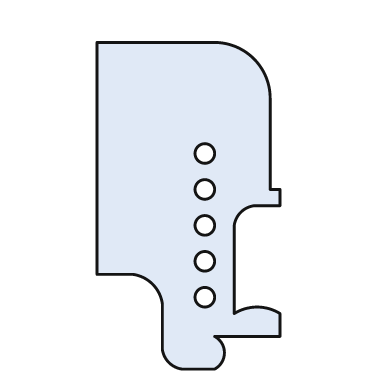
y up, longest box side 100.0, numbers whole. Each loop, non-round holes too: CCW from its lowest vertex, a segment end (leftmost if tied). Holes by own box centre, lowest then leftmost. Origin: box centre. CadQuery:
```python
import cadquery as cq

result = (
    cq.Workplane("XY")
    .moveTo(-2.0, -50.0)
    .lineTo(8.0, -50.0)
    .threePointArc((11.0, -45.0), (8.0, -40.0))
    .lineTo(28.0, -40.0)
    .lineTo(28.0, -33.0)
    .threePointArc((21.0, -31.0), (14.0, -33.0))
    .lineTo(14.0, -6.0)
    .threePointArc((16.0, -2.0), (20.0, 0.0))
    .lineTo(28.0, 0.0)
    .lineTo(28.0, 5.0)
    .lineTo(25.0, 5.0)
    .lineTo(25.0, 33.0)
    .threePointArc((20.0, 45.0), (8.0, 50.0))
    .lineTo(-28.0, 50.0)
    .lineTo(-28.0, -21.0)
    .lineTo(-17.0, -21.0)
    .threePointArc((-11.0, -24.0), (-8.0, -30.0))
    .lineTo(-8.0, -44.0)
    .threePointArc((-6.0, -48.0), (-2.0, -50.0))
    .close()
    .moveTo(5.0, -28.0)
    .circle(3.0)
    .moveTo(5.0, -17.0)
    .circle(3.0)
    .moveTo(5.0, -6.0)
    .circle(3.0)
    .moveTo(5.0, 5.0)
    .circle(3.0)
    .moveTo(5.0, 16.0)
    .circle(3.0)
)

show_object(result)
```